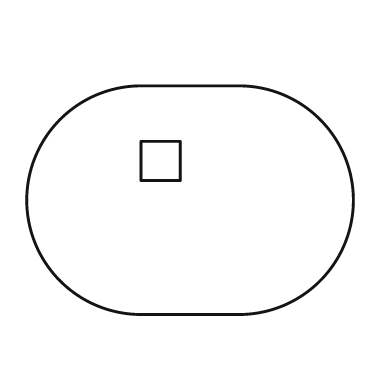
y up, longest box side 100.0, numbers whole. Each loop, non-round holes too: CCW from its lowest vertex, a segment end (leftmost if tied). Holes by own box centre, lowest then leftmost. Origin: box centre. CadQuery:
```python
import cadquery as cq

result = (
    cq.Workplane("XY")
    .moveTo(-15.0, -35.0)
    .lineTo(15.0, -35.0)
    .threePointArc((50.0, 0.0), (15.0, 35.0))
    .lineTo(-15.0, 35.0)
    .threePointArc((-50.0, 0.0), (-15.0, -35.0))
    .close()
    .moveTo(-15.0, 6.0)
    .lineTo(-3.0, 6.0)
    .lineTo(-3.0, 18.0)
    .lineTo(-15.0, 18.0)
    .close()
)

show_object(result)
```